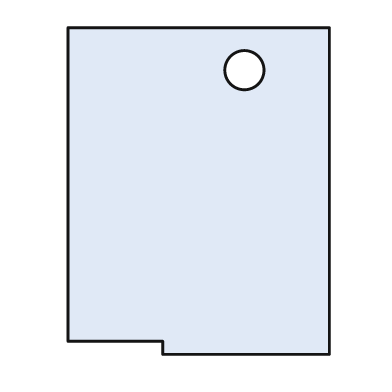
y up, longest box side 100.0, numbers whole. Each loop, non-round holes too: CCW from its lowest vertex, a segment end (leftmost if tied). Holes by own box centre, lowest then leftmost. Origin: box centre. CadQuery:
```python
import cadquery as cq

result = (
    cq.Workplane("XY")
    .moveTo(-11.0, -50.0)
    .lineTo(40.0, -50.0)
    .lineTo(40.0, 50.0)
    .lineTo(-40.0, 50.0)
    .lineTo(-40.0, -46.0)
    .lineTo(-11.0, -46.0)
    .close()
    .moveTo(14.0, 37.0)
    .circle(6.0)
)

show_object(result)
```